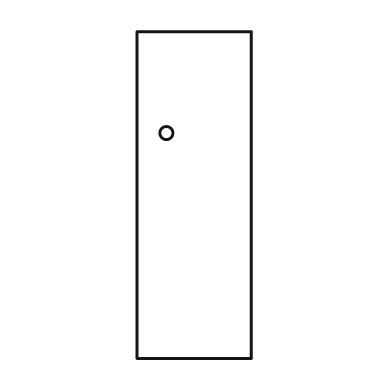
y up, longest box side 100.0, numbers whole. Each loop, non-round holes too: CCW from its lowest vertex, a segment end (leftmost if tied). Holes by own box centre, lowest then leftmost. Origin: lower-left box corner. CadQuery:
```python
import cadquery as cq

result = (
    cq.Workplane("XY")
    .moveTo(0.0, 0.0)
    .lineTo(35.0, 0.0)
    .lineTo(35.0, 100.0)
    .lineTo(0.0, 100.0)
    .close()
    .moveTo(9.0, 69.0)
    .circle(2.0)
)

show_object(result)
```